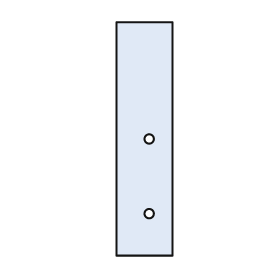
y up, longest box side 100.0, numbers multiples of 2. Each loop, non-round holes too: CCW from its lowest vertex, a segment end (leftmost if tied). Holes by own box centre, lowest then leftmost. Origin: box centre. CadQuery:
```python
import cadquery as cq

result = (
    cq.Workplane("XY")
    .moveTo(-12.0, -50.0)
    .lineTo(12.0, -50.0)
    .lineTo(12.0, 50.0)
    .lineTo(-12.0, 50.0)
    .close()
    .moveTo(2.0, -32.0)
    .circle(2.0)
    .moveTo(2.0, 0.0)
    .circle(2.0)
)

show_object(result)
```